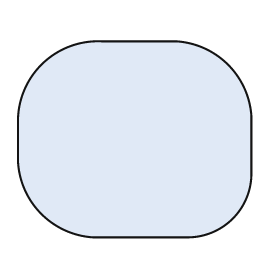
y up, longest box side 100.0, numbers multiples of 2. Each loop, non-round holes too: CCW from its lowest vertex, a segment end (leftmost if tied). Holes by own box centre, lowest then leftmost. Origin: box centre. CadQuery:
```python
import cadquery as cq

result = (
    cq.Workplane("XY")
    .moveTo(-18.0, -42.0)
    .lineTo(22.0, -42.0)
    .threePointArc((42.0, -34.0), (50.0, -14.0))
    .lineTo(50.0, 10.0)
    .threePointArc((40.0, 32.0), (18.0, 42.0))
    .lineTo(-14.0, 42.0)
    .threePointArc((-40.0, 32.0), (-50.0, 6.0))
    .lineTo(-50.0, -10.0)
    .threePointArc((-40.0, -32.0), (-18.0, -42.0))
    .close()
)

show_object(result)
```